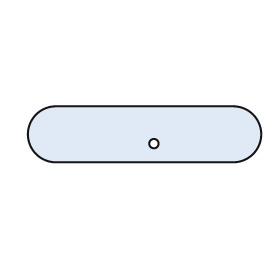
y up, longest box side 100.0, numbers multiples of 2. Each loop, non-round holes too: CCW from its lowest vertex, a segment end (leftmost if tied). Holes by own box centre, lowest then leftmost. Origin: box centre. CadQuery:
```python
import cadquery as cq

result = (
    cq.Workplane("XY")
    .moveTo(-38.0, -12.0)
    .lineTo(38.0, -12.0)
    .threePointArc((50.0, 0.0), (38.0, 12.0))
    .lineTo(-38.0, 12.0)
    .threePointArc((-50.0, 0.0), (-38.0, -12.0))
    .close()
    .moveTo(4.0, -4.0)
    .circle(2.0)
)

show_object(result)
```